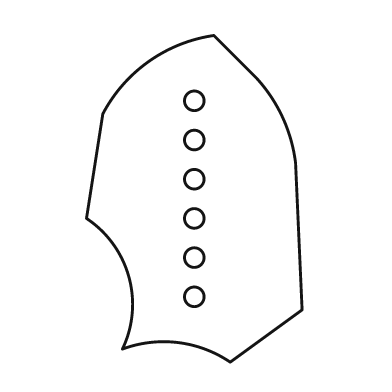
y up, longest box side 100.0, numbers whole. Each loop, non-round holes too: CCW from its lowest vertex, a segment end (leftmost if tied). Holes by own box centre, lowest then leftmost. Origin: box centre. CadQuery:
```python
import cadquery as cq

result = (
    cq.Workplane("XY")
    .moveTo(11.0, -50.0)
    .lineTo(33.0, -34.0)
    .lineTo(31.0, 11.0)
    .threePointArc((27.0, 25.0), (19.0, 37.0))
    .lineTo(6.0, 50.0)
    .threePointArc((-14.0, 42.0), (-28.0, 26.0))
    .lineTo(-33.0, -6.0)
    .threePointArc((-20.0, -24.0), (-22.0, -46.0))
    .threePointArc((-5.0, -44.0), (11.0, -50.0))
    .close()
    .moveTo(0.0, -30.0)
    .circle(3.0)
    .moveTo(0.0, -18.0)
    .circle(3.0)
    .moveTo(0.0, -6.0)
    .circle(3.0)
    .moveTo(0.0, 6.0)
    .circle(3.0)
    .moveTo(0.0, 18.0)
    .circle(3.0)
    .moveTo(0.0, 30.0)
    .circle(3.0)
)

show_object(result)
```